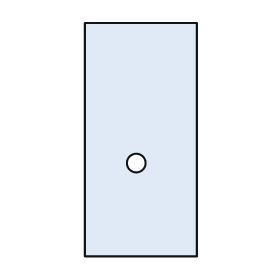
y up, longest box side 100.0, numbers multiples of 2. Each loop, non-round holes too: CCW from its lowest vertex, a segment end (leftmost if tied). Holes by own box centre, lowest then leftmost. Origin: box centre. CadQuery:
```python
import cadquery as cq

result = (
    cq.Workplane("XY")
    .moveTo(-24.0, -50.0)
    .lineTo(24.0, -50.0)
    .lineTo(24.0, 50.0)
    .lineTo(-24.0, 50.0)
    .close()
    .moveTo(-2.0, -10.0)
    .circle(4.0)
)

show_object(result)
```